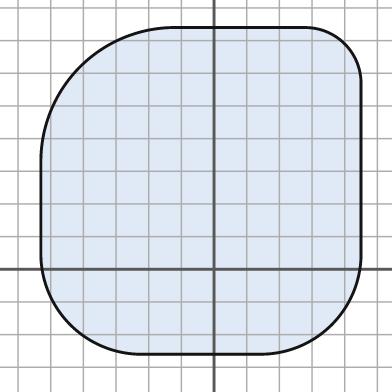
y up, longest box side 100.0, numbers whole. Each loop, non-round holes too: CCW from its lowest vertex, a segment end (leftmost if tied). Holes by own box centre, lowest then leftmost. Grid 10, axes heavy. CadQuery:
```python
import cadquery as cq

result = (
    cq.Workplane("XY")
    .moveTo(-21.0, -26.0)
    .lineTo(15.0, -26.0)
    .threePointArc((36.0, -17.0), (45.0, 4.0))
    .lineTo(45.0, 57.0)
    .threePointArc((40.0, 69.0), (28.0, 74.0))
    .lineTo(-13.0, 74.0)
    .threePointArc((-41.0, 62.0), (-53.0, 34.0))
    .lineTo(-53.0, 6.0)
    .threePointArc((-44.0, -17.0), (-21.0, -26.0))
    .close()
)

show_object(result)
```